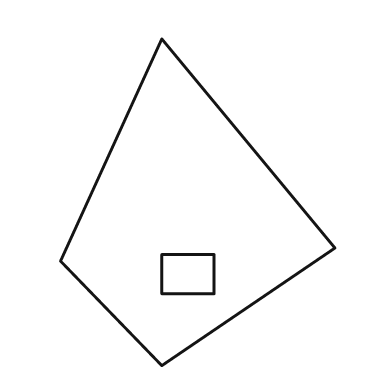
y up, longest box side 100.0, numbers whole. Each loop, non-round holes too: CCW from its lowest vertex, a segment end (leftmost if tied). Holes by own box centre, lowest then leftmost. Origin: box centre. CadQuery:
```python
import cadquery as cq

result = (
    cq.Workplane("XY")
    .moveTo(-11.0, -50.0)
    .lineTo(42.0, -14.0)
    .lineTo(-11.0, 50.0)
    .lineTo(-42.0, -18.0)
    .close()
    .moveTo(-11.0, -28.0)
    .lineTo(5.0, -28.0)
    .lineTo(5.0, -16.0)
    .lineTo(-11.0, -16.0)
    .close()
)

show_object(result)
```